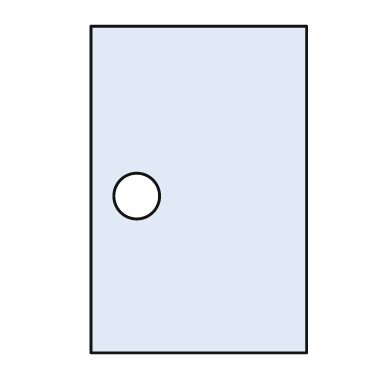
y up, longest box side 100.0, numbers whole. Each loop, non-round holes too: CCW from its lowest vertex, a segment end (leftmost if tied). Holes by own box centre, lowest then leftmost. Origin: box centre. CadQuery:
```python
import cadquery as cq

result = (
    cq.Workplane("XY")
    .moveTo(-33.0, -50.0)
    .lineTo(33.0, -50.0)
    .lineTo(33.0, 50.0)
    .lineTo(-33.0, 50.0)
    .close()
    .moveTo(-19.0, -2.0)
    .circle(7.0)
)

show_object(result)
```